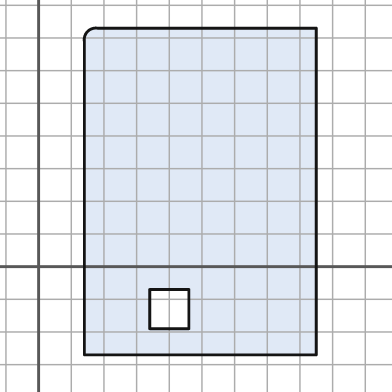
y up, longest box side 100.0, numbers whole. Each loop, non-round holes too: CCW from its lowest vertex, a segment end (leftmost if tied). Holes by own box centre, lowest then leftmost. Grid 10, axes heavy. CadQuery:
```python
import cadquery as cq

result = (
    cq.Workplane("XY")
    .moveTo(14.0, -27.0)
    .lineTo(85.0, -27.0)
    .lineTo(85.0, 73.0)
    .lineTo(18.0, 73.0)
    .threePointArc((15.0, 72.0), (14.0, 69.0))
    .close()
    .moveTo(34.0, -19.0)
    .lineTo(46.0, -19.0)
    .lineTo(46.0, -7.0)
    .lineTo(34.0, -7.0)
    .close()
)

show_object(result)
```